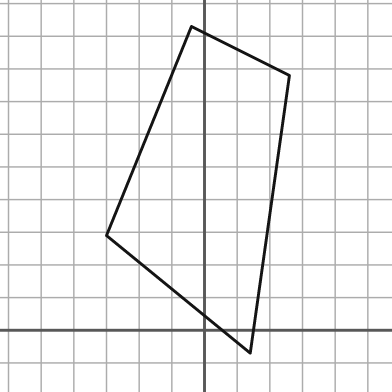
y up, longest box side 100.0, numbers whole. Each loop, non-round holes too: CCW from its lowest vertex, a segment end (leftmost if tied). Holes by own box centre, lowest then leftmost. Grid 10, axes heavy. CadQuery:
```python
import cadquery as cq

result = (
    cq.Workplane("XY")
    .moveTo(14.0, -7.0)
    .lineTo(26.0, 78.0)
    .lineTo(-4.0, 93.0)
    .lineTo(-30.0, 29.0)
    .close()
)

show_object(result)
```